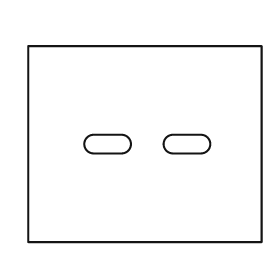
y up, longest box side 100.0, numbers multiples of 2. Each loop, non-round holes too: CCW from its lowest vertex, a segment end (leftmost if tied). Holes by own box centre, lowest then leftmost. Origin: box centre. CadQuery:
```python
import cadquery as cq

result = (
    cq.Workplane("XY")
    .moveTo(-50.0, -42.0)
    .lineTo(50.0, -42.0)
    .lineTo(50.0, 42.0)
    .lineTo(-50.0, 42.0)
    .close()
    .moveTo(-22.0, -4.0)
    .lineTo(-10.0, -4.0)
    .threePointArc((-6.0, 0.0), (-10.0, 4.0))
    .lineTo(-22.0, 4.0)
    .threePointArc((-26.0, 0.0), (-22.0, -4.0))
    .close()
    .moveTo(12.0, -4.0)
    .lineTo(24.0, -4.0)
    .threePointArc((28.0, 0.0), (24.0, 4.0))
    .lineTo(12.0, 4.0)
    .threePointArc((8.0, 0.0), (12.0, -4.0))
    .close()
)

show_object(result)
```